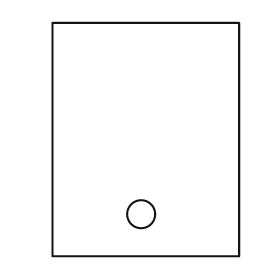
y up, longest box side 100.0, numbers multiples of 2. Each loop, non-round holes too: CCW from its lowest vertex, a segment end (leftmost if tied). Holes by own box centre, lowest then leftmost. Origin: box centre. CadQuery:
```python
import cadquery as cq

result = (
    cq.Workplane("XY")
    .moveTo(-40.0, -50.0)
    .lineTo(40.0, -50.0)
    .lineTo(40.0, 50.0)
    .lineTo(-40.0, 50.0)
    .close()
    .moveTo(-2.0, -32.0)
    .circle(6.0)
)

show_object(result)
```